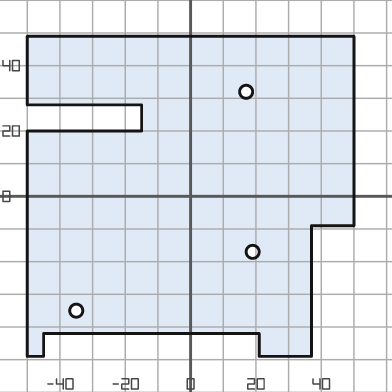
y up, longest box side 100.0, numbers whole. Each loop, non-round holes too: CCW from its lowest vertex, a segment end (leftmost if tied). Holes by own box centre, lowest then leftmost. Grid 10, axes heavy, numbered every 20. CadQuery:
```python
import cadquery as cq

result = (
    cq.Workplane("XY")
    .moveTo(-50.0, -49.0)
    .lineTo(-45.0, -49.0)
    .lineTo(-45.0, -42.0)
    .lineTo(21.0, -42.0)
    .lineTo(21.0, -49.0)
    .lineTo(37.0, -49.0)
    .lineTo(37.0, -9.0)
    .lineTo(50.0, -9.0)
    .lineTo(50.0, 49.0)
    .lineTo(-50.0, 49.0)
    .lineTo(-50.0, 28.0)
    .lineTo(-15.0, 28.0)
    .lineTo(-15.0, 20.0)
    .lineTo(-50.0, 20.0)
    .close()
    .moveTo(-35.0, -35.0)
    .circle(2.0)
    .moveTo(19.0, -17.0)
    .circle(2.0)
    .moveTo(17.0, 32.0)
    .circle(2.0)
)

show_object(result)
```